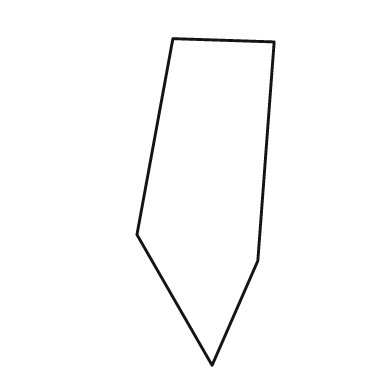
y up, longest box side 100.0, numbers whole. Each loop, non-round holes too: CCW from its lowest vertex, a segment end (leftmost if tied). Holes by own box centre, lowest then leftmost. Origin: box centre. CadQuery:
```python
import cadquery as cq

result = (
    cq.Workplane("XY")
    .moveTo(2.0, -50.0)
    .lineTo(16.0, -18.0)
    .lineTo(21.0, 49.0)
    .lineTo(-10.0, 50.0)
    .lineTo(-21.0, -10.0)
    .close()
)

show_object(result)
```